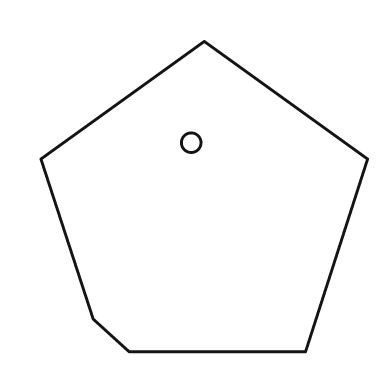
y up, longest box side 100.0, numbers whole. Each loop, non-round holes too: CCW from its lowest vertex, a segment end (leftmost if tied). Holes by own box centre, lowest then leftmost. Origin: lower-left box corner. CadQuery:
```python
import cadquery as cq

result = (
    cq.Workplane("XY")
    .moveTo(27.0, 0.0)
    .lineTo(81.0, 0.0)
    .lineTo(100.0, 59.0)
    .lineTo(50.0, 95.0)
    .lineTo(0.0, 59.0)
    .lineTo(16.0, 10.0)
    .close()
    .moveTo(46.0, 64.0)
    .circle(3.0)
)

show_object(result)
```